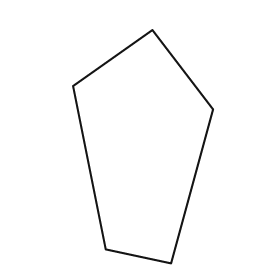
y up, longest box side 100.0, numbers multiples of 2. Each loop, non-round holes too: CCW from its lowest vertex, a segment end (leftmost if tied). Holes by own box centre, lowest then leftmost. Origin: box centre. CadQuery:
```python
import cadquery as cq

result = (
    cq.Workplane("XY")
    .moveTo(12.0, -50.0)
    .lineTo(30.0, 16.0)
    .lineTo(4.0, 50.0)
    .lineTo(-30.0, 26.0)
    .lineTo(-16.0, -44.0)
    .close()
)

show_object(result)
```